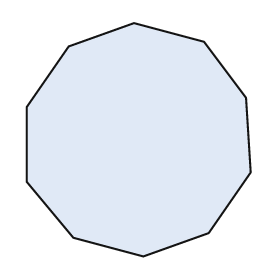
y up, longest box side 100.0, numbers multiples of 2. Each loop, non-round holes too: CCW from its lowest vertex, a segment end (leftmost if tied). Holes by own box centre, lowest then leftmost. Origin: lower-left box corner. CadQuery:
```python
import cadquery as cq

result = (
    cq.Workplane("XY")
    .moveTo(50.0, 0.0)
    .lineTo(78.0, 10.0)
    .lineTo(96.0, 36.0)
    .lineTo(94.0, 68.0)
    .lineTo(76.0, 92.0)
    .lineTo(46.0, 100.0)
    .lineTo(18.0, 90.0)
    .lineTo(0.0, 64.0)
    .lineTo(0.0, 32.0)
    .lineTo(20.0, 8.0)
    .close()
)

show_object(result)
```